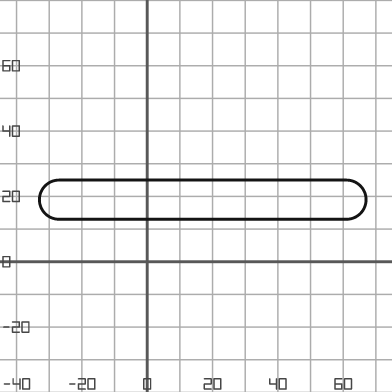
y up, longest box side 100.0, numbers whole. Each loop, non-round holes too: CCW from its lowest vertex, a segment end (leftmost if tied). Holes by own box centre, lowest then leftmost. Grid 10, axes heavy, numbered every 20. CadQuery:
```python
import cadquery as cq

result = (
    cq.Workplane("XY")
    .moveTo(-27.0, 13.0)
    .lineTo(61.0, 13.0)
    .threePointArc((67.0, 19.0), (61.0, 25.0))
    .lineTo(-27.0, 25.0)
    .threePointArc((-33.0, 19.0), (-27.0, 13.0))
    .close()
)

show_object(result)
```